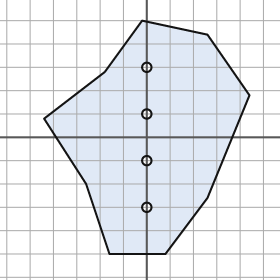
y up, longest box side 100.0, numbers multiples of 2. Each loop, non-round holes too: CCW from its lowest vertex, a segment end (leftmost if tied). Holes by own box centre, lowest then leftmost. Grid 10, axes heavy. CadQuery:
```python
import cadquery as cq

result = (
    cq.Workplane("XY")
    .moveTo(-16.0, -50.0)
    .lineTo(8.0, -50.0)
    .lineTo(26.0, -26.0)
    .lineTo(44.0, 18.0)
    .lineTo(26.0, 44.0)
    .lineTo(-2.0, 50.0)
    .lineTo(-18.0, 28.0)
    .lineTo(-44.0, 8.0)
    .lineTo(-26.0, -20.0)
    .close()
    .moveTo(0.0, -30.0)
    .circle(2.0)
    .moveTo(0.0, -10.0)
    .circle(2.0)
    .moveTo(0.0, 10.0)
    .circle(2.0)
    .moveTo(0.0, 30.0)
    .circle(2.0)
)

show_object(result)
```